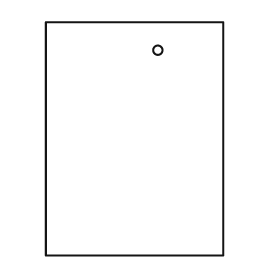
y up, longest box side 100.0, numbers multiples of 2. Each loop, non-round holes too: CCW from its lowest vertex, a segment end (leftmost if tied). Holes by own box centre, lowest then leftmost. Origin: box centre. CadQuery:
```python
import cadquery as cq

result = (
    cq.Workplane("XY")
    .moveTo(-38.0, -50.0)
    .lineTo(38.0, -50.0)
    .lineTo(38.0, 50.0)
    .lineTo(-38.0, 50.0)
    .close()
    .moveTo(10.0, 38.0)
    .circle(2.0)
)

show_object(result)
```